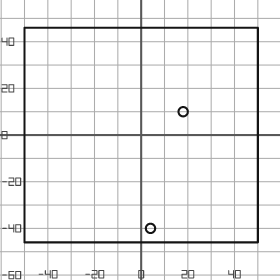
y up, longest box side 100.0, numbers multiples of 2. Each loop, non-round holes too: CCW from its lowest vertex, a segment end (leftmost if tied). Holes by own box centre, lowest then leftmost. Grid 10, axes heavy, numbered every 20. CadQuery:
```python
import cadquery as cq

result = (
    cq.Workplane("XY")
    .moveTo(-50.0, -46.0)
    .lineTo(50.0, -46.0)
    .lineTo(50.0, 46.0)
    .lineTo(-50.0, 46.0)
    .close()
    .moveTo(4.0, -40.0)
    .circle(2.0)
    .moveTo(18.0, 10.0)
    .circle(2.0)
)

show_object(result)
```